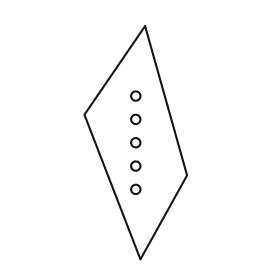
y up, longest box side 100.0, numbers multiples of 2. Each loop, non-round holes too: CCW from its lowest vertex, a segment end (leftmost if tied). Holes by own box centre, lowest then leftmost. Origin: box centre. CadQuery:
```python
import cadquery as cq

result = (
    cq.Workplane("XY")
    .moveTo(2.0, -50.0)
    .lineTo(22.0, -14.0)
    .lineTo(4.0, 50.0)
    .lineTo(-22.0, 12.0)
    .close()
    .moveTo(0.0, -20.0)
    .circle(2.0)
    .moveTo(0.0, -10.0)
    .circle(2.0)
    .moveTo(0.0, 0.0)
    .circle(2.0)
    .moveTo(0.0, 10.0)
    .circle(2.0)
    .moveTo(0.0, 20.0)
    .circle(2.0)
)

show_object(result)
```